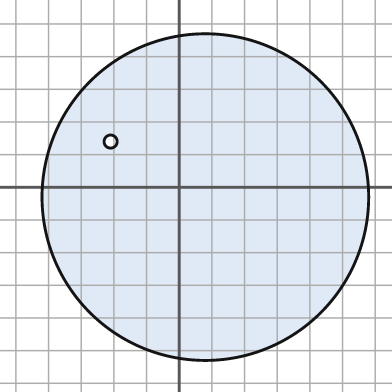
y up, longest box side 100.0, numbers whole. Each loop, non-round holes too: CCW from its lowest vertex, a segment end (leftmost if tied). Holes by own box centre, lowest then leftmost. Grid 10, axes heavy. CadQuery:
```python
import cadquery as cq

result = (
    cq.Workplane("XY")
    .moveTo(8.0, -3.0)
    .circle(50.0)
    .moveTo(-21.0, 14.0)
    .circle(2.0)
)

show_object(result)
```